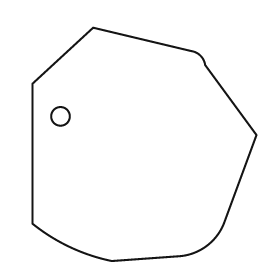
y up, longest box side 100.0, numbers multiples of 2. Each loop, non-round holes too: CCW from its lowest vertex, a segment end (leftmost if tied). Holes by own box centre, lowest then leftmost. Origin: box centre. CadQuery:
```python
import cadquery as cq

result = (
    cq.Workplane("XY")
    .moveTo(-14.0, -50.0)
    .lineTo(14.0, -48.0)
    .threePointArc((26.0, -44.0), (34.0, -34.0))
    .lineTo(48.0, 4.0)
    .lineTo(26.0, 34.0)
    .threePointArc((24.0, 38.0), (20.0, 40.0))
    .lineTo(-22.0, 50.0)
    .lineTo(-48.0, 26.0)
    .lineTo(-48.0, -34.0)
    .threePointArc((-32.0, -44.0), (-14.0, -50.0))
    .close()
    .moveTo(-36.0, 12.0)
    .circle(4.0)
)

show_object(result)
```